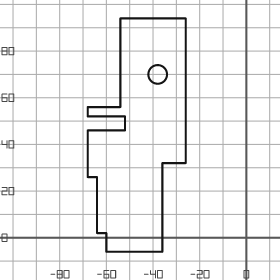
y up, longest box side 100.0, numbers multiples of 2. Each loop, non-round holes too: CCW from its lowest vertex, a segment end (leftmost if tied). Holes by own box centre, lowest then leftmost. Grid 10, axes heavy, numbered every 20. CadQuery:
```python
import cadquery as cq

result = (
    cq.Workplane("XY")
    .moveTo(-60.0, -6.0)
    .lineTo(-36.0, -6.0)
    .lineTo(-36.0, 32.0)
    .lineTo(-26.0, 32.0)
    .lineTo(-26.0, 94.0)
    .lineTo(-54.0, 94.0)
    .lineTo(-54.0, 56.0)
    .lineTo(-68.0, 56.0)
    .lineTo(-68.0, 52.0)
    .lineTo(-52.0, 52.0)
    .lineTo(-52.0, 46.0)
    .lineTo(-68.0, 46.0)
    .lineTo(-68.0, 26.0)
    .lineTo(-64.0, 26.0)
    .lineTo(-64.0, 2.0)
    .lineTo(-60.0, 2.0)
    .close()
    .moveTo(-38.0, 70.0)
    .circle(4.0)
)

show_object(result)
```